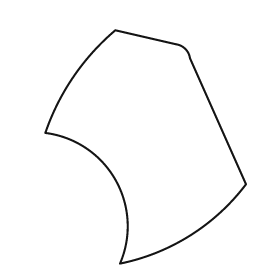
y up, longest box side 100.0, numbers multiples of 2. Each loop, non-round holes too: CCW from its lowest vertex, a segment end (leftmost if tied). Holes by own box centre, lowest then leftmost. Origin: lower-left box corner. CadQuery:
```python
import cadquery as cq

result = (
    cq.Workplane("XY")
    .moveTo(32.0, 0.0)
    .threePointArc((62.0, 12.0), (86.0, 34.0))
    .lineTo(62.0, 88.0)
    .threePointArc((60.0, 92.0), (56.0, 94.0))
    .lineTo(30.0, 100.0)
    .threePointArc((12.0, 80.0), (0.0, 56.0))
    .threePointArc((30.0, 36.0), (32.0, 0.0))
    .close()
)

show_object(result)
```